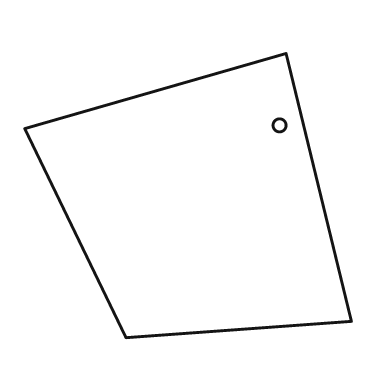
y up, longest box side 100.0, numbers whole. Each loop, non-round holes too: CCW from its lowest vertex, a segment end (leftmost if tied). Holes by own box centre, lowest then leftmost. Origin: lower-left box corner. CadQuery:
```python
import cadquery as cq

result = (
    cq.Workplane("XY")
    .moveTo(31.0, 0.0)
    .lineTo(100.0, 5.0)
    .lineTo(80.0, 87.0)
    .lineTo(0.0, 64.0)
    .close()
    .moveTo(78.0, 65.0)
    .circle(2.0)
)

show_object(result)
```